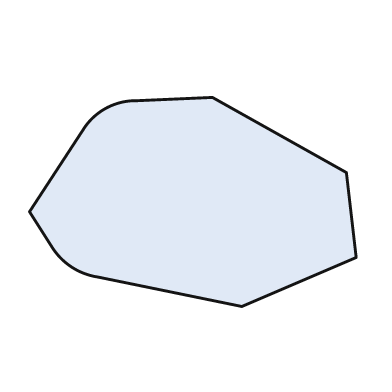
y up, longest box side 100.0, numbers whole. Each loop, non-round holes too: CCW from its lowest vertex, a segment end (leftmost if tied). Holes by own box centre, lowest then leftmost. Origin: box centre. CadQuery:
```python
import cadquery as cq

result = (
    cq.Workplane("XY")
    .moveTo(15.0, -32.0)
    .lineTo(50.0, -17.0)
    .lineTo(47.0, 9.0)
    .lineTo(6.0, 32.0)
    .lineTo(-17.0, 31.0)
    .threePointArc((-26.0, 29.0), (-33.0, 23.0))
    .lineTo(-50.0, -3.0)
    .lineTo(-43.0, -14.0)
    .threePointArc((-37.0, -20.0), (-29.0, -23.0))
    .close()
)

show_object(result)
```